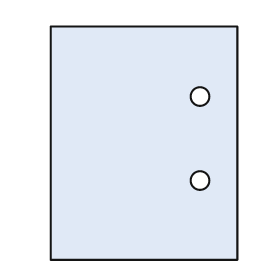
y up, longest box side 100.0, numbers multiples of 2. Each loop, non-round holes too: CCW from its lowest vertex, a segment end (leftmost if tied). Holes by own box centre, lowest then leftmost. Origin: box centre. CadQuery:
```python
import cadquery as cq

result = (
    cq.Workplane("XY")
    .moveTo(-40.0, -50.0)
    .lineTo(40.0, -50.0)
    .lineTo(40.0, 50.0)
    .lineTo(-40.0, 50.0)
    .close()
    .moveTo(24.0, -16.0)
    .circle(4.0)
    .moveTo(24.0, 20.0)
    .circle(4.0)
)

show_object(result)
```